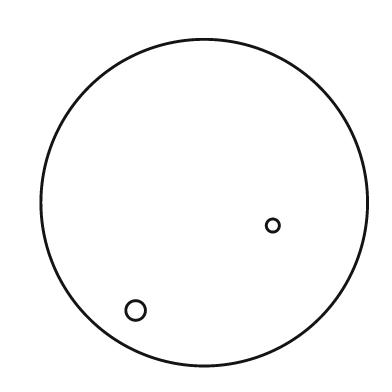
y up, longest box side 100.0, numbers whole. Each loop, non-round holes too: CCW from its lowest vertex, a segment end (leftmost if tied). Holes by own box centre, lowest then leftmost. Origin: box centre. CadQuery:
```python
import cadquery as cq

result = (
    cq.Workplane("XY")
    .moveTo(0.0, 0.0)
    .circle(50.0)
    .moveTo(-21.0, -33.0)
    .circle(3.0)
    .moveTo(21.0, -7.0)
    .circle(2.0)
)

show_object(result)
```